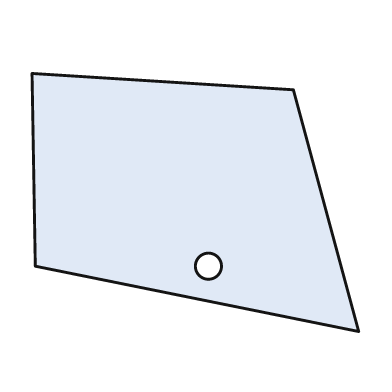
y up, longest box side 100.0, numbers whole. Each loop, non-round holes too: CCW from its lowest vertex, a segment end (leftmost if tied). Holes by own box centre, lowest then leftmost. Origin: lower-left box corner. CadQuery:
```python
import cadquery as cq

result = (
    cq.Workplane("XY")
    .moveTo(100.0, 0.0)
    .lineTo(80.0, 74.0)
    .lineTo(0.0, 79.0)
    .lineTo(1.0, 20.0)
    .close()
    .moveTo(54.0, 20.0)
    .circle(4.0)
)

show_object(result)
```